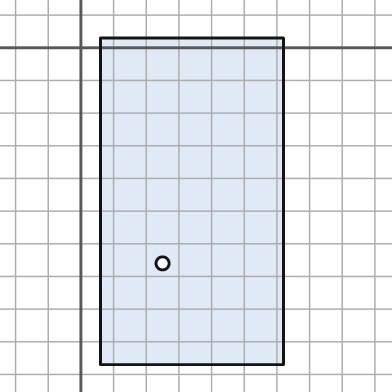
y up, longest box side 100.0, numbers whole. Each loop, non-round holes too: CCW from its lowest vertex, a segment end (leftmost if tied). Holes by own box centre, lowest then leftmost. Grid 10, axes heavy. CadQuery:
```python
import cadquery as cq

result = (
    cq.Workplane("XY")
    .moveTo(6.0, -97.0)
    .lineTo(62.0, -97.0)
    .lineTo(62.0, 3.0)
    .lineTo(6.0, 3.0)
    .close()
    .moveTo(25.0, -66.0)
    .circle(2.0)
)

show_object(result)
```